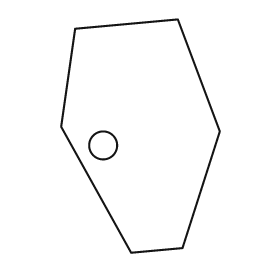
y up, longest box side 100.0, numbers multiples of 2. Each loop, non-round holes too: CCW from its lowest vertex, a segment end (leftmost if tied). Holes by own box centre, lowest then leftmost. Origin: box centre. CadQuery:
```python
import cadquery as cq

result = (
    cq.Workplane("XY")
    .moveTo(-4.0, -50.0)
    .lineTo(18.0, -48.0)
    .lineTo(34.0, 2.0)
    .lineTo(16.0, 50.0)
    .lineTo(-28.0, 46.0)
    .lineTo(-34.0, 4.0)
    .close()
    .moveTo(-16.0, -4.0)
    .circle(6.0)
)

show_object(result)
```